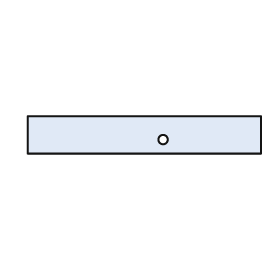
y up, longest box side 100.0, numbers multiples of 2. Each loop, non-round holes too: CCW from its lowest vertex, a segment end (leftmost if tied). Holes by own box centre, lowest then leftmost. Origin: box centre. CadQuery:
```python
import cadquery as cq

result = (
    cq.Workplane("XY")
    .moveTo(-50.0, -8.0)
    .lineTo(50.0, -8.0)
    .lineTo(50.0, 8.0)
    .lineTo(-50.0, 8.0)
    .close()
    .moveTo(8.0, -2.0)
    .circle(2.0)
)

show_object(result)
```